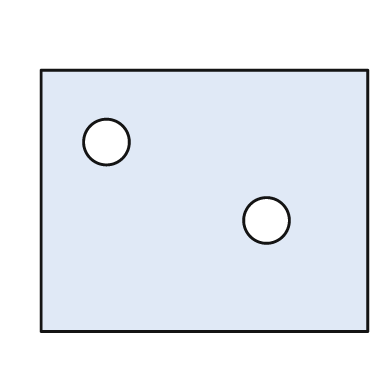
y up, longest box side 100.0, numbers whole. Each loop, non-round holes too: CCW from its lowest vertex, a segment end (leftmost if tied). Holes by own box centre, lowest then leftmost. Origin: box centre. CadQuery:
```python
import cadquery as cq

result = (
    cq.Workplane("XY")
    .moveTo(-50.0, -40.0)
    .lineTo(50.0, -40.0)
    .lineTo(50.0, 40.0)
    .lineTo(-50.0, 40.0)
    .close()
    .moveTo(19.0, -6.0)
    .circle(7.0)
    .moveTo(-30.0, 18.0)
    .circle(7.0)
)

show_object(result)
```